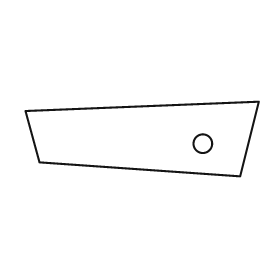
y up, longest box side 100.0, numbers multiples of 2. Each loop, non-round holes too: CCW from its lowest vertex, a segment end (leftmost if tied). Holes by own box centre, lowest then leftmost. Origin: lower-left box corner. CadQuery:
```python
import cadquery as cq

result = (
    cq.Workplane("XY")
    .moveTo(92.0, 0.0)
    .lineTo(100.0, 32.0)
    .lineTo(0.0, 28.0)
    .lineTo(6.0, 6.0)
    .close()
    .moveTo(76.0, 14.0)
    .circle(4.0)
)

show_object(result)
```